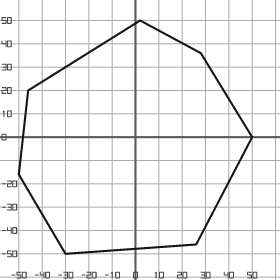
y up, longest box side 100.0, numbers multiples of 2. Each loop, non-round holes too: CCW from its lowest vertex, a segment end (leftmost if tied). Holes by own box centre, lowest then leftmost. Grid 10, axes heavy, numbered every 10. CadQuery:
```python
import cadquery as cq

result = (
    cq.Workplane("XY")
    .moveTo(-30.0, -50.0)
    .lineTo(26.0, -46.0)
    .lineTo(50.0, 0.0)
    .lineTo(28.0, 36.0)
    .lineTo(2.0, 50.0)
    .lineTo(-46.0, 20.0)
    .lineTo(-50.0, -16.0)
    .close()
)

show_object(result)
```